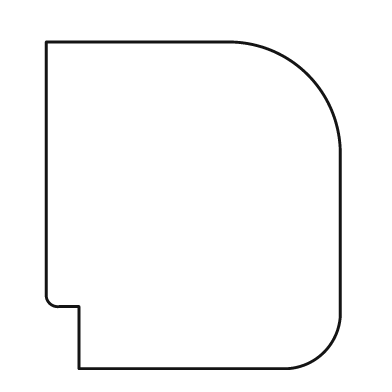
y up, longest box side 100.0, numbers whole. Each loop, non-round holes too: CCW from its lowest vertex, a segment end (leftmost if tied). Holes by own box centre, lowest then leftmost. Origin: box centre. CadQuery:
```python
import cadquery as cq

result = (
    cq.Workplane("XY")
    .moveTo(-35.0, -50.0)
    .lineTo(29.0, -50.0)
    .threePointArc((40.0, -45.0), (45.0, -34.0))
    .lineTo(45.0, 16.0)
    .threePointArc((35.0, 40.0), (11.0, 50.0))
    .lineTo(-45.0, 50.0)
    .lineTo(-45.0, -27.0)
    .threePointArc((-44.0, -30.0), (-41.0, -31.0))
    .lineTo(-35.0, -31.0)
    .close()
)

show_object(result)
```